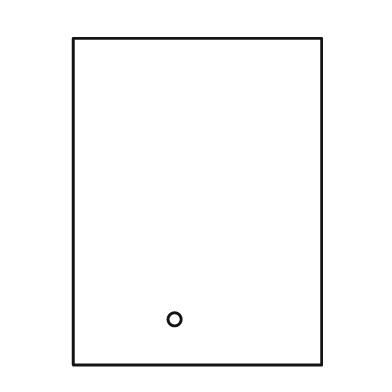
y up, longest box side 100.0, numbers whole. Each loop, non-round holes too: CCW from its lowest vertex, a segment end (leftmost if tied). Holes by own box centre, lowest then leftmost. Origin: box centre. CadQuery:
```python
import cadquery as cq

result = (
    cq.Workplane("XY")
    .moveTo(-38.0, -50.0)
    .lineTo(38.0, -50.0)
    .lineTo(38.0, 50.0)
    .lineTo(-38.0, 50.0)
    .close()
    .moveTo(-7.0, -36.0)
    .circle(2.0)
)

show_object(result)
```